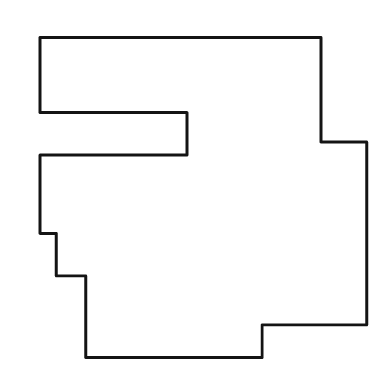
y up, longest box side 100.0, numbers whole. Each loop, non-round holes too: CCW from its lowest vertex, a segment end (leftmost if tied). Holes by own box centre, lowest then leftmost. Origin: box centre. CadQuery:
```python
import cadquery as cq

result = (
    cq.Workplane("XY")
    .moveTo(-36.0, -49.0)
    .lineTo(18.0, -49.0)
    .lineTo(18.0, -39.0)
    .lineTo(50.0, -39.0)
    .lineTo(50.0, 17.0)
    .lineTo(36.0, 17.0)
    .lineTo(36.0, 49.0)
    .lineTo(-50.0, 49.0)
    .lineTo(-50.0, 26.0)
    .lineTo(-5.0, 26.0)
    .lineTo(-5.0, 13.0)
    .lineTo(-50.0, 13.0)
    .lineTo(-50.0, -11.0)
    .lineTo(-45.0, -11.0)
    .lineTo(-45.0, -24.0)
    .lineTo(-36.0, -24.0)
    .close()
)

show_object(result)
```